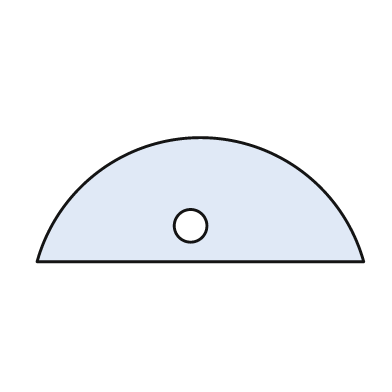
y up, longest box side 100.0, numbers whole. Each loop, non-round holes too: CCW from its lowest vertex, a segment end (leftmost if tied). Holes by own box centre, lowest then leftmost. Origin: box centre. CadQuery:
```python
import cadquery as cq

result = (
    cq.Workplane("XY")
    .moveTo(-50.0, -19.0)
    .lineTo(50.0, -19.0)
    .threePointArc((0.0, 19.0), (-50.0, -19.0))
    .close()
    .moveTo(-3.0, -8.0)
    .circle(5.0)
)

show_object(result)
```